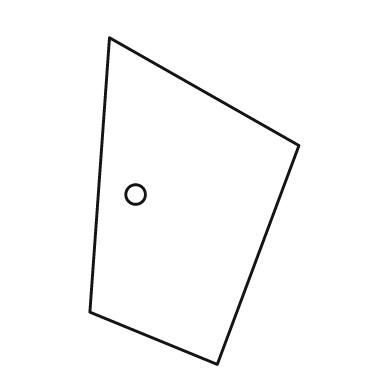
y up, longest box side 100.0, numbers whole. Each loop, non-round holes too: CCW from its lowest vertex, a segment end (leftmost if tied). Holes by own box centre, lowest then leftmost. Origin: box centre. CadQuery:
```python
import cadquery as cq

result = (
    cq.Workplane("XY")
    .moveTo(7.0, -50.0)
    .lineTo(32.0, 17.0)
    .lineTo(-26.0, 50.0)
    .lineTo(-32.0, -34.0)
    .close()
    .moveTo(-18.0, 2.0)
    .circle(3.0)
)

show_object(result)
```